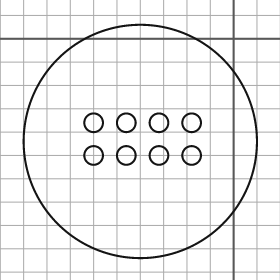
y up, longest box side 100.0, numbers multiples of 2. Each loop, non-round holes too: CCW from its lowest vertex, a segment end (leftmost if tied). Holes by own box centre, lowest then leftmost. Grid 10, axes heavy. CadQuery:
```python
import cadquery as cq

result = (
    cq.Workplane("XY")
    .moveTo(-40.0, -44.0)
    .circle(50.0)
    .moveTo(-60.0, -50.0)
    .circle(4.0)
    .moveTo(-46.0, -50.0)
    .circle(4.0)
    .moveTo(-32.0, -50.0)
    .circle(4.0)
    .moveTo(-18.0, -50.0)
    .circle(4.0)
    .moveTo(-60.0, -36.0)
    .circle(4.0)
    .moveTo(-46.0, -36.0)
    .circle(4.0)
    .moveTo(-32.0, -36.0)
    .circle(4.0)
    .moveTo(-18.0, -36.0)
    .circle(4.0)
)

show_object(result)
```